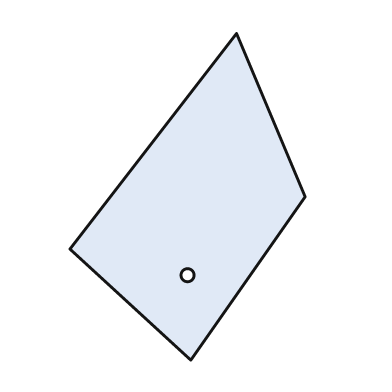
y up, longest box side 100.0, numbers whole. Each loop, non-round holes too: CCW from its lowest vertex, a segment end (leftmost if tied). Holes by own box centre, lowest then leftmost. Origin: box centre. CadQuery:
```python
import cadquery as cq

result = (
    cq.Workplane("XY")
    .moveTo(1.0, -50.0)
    .lineTo(36.0, 0.0)
    .lineTo(15.0, 50.0)
    .lineTo(-36.0, -16.0)
    .close()
    .moveTo(0.0, -24.0)
    .circle(2.0)
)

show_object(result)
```